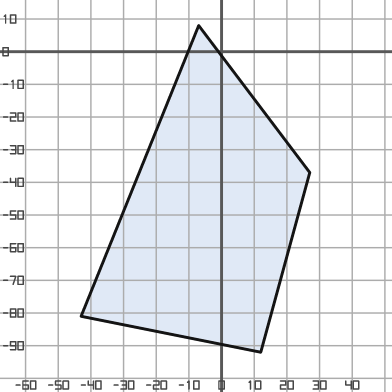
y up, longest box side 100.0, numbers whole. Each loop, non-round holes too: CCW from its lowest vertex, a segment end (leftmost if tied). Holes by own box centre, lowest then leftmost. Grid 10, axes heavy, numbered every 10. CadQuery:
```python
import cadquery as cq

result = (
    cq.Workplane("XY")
    .moveTo(12.0, -92.0)
    .lineTo(27.0, -37.0)
    .lineTo(-7.0, 8.0)
    .lineTo(-43.0, -81.0)
    .close()
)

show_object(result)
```